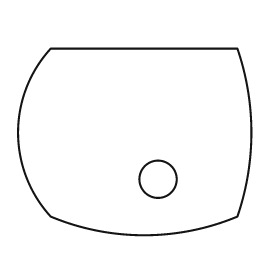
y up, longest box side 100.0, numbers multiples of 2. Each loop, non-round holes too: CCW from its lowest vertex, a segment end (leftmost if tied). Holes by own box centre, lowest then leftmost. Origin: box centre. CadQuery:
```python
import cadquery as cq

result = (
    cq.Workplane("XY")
    .moveTo(-36.0, -32.0)
    .threePointArc((4.0, -40.0), (44.0, -32.0))
    .threePointArc((50.0, 4.0), (44.0, 40.0))
    .lineTo(-36.0, 40.0)
    .threePointArc((-50.0, 4.0), (-36.0, -32.0))
    .close()
    .moveTo(10.0, -16.0)
    .circle(8.0)
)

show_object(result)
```